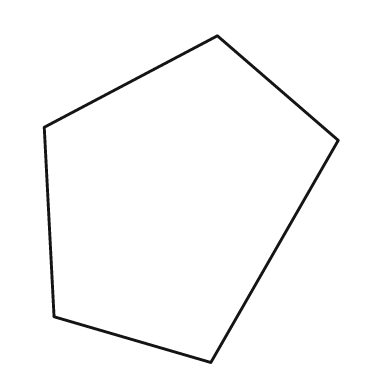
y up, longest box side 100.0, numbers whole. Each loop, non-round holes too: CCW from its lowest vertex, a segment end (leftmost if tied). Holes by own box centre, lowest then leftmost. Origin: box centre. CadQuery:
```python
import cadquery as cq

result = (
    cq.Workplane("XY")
    .moveTo(6.0, -50.0)
    .lineTo(45.0, 18.0)
    .lineTo(8.0, 50.0)
    .lineTo(-45.0, 22.0)
    .lineTo(-42.0, -36.0)
    .close()
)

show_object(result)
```